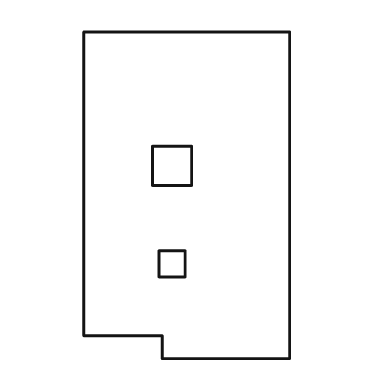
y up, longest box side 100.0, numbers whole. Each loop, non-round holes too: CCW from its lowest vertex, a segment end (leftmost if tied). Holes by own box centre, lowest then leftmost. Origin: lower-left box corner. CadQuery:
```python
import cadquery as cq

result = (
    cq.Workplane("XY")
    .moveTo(24.0, 0.0)
    .lineTo(63.0, 0.0)
    .lineTo(63.0, 100.0)
    .lineTo(0.0, 100.0)
    .lineTo(0.0, 7.0)
    .lineTo(24.0, 7.0)
    .close()
    .moveTo(23.0, 25.0)
    .lineTo(31.0, 25.0)
    .lineTo(31.0, 33.0)
    .lineTo(23.0, 33.0)
    .close()
    .moveTo(21.0, 53.0)
    .lineTo(33.0, 53.0)
    .lineTo(33.0, 65.0)
    .lineTo(21.0, 65.0)
    .close()
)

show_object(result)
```